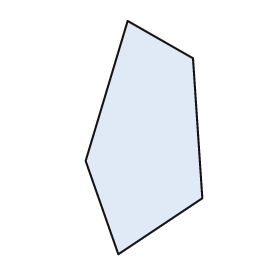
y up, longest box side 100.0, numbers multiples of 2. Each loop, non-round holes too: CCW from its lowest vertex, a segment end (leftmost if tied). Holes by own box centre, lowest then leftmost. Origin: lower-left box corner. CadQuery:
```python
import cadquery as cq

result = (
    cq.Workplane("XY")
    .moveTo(14.0, 0.0)
    .lineTo(50.0, 24.0)
    .lineTo(46.0, 84.0)
    .lineTo(18.0, 100.0)
    .lineTo(0.0, 40.0)
    .close()
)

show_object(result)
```